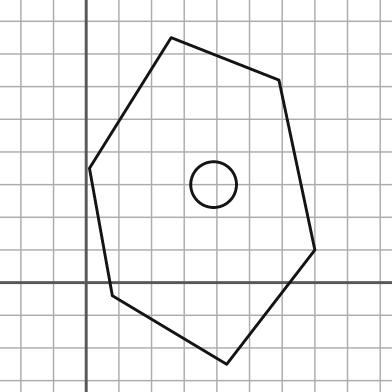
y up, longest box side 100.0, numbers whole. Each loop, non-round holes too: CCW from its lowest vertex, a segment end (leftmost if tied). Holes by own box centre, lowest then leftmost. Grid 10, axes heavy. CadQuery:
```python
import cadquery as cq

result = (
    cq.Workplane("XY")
    .moveTo(43.0, -25.0)
    .lineTo(70.0, 10.0)
    .lineTo(59.0, 62.0)
    .lineTo(26.0, 75.0)
    .lineTo(1.0, 35.0)
    .lineTo(8.0, -4.0)
    .close()
    .moveTo(39.0, 30.0)
    .circle(7.0)
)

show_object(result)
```